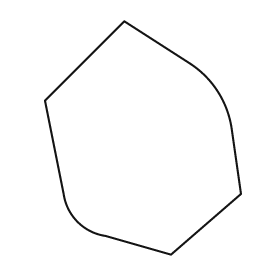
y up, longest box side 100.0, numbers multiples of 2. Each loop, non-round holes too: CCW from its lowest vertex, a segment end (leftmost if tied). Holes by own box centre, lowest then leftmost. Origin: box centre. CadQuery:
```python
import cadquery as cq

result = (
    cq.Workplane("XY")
    .moveTo(12.0, -50.0)
    .lineTo(42.0, -24.0)
    .lineTo(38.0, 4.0)
    .threePointArc((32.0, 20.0), (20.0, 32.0))
    .lineTo(-8.0, 50.0)
    .lineTo(-42.0, 16.0)
    .lineTo(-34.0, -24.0)
    .threePointArc((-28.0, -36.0), (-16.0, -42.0))
    .close()
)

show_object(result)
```